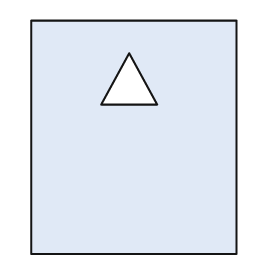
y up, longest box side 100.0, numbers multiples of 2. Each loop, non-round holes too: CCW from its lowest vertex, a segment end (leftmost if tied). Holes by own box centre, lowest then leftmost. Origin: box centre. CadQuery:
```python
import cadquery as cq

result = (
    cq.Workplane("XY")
    .moveTo(-44.0, -50.0)
    .lineTo(44.0, -50.0)
    .lineTo(44.0, 50.0)
    .lineTo(-44.0, 50.0)
    .close()
    .moveTo(-14.0, 14.0)
    .lineTo(10.0, 14.0)
    .lineTo(-2.0, 36.0)
    .close()
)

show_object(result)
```